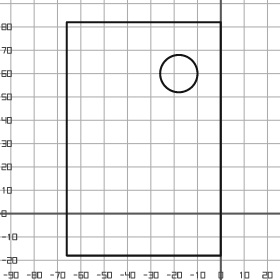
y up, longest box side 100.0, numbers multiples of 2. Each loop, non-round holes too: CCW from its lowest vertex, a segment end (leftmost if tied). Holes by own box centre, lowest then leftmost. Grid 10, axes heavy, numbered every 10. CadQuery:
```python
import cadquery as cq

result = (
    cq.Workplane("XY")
    .moveTo(-66.0, -18.0)
    .lineTo(0.0, -18.0)
    .lineTo(0.0, 82.0)
    .lineTo(-66.0, 82.0)
    .close()
    .moveTo(-18.0, 60.0)
    .circle(8.0)
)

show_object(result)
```